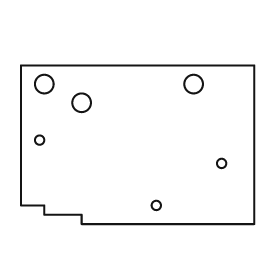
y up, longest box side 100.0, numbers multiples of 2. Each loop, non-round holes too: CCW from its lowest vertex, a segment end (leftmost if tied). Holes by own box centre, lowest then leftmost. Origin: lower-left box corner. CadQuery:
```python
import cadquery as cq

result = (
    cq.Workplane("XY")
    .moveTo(26.0, 0.0)
    .lineTo(100.0, 0.0)
    .lineTo(100.0, 68.0)
    .lineTo(0.0, 68.0)
    .lineTo(0.0, 8.0)
    .lineTo(10.0, 8.0)
    .lineTo(10.0, 4.0)
    .lineTo(26.0, 4.0)
    .close()
    .moveTo(58.0, 8.0)
    .circle(2.0)
    .moveTo(86.0, 26.0)
    .circle(2.0)
    .moveTo(8.0, 36.0)
    .circle(2.0)
    .moveTo(26.0, 52.0)
    .circle(4.0)
    .moveTo(10.0, 60.0)
    .circle(4.0)
    .moveTo(74.0, 60.0)
    .circle(4.0)
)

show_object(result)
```